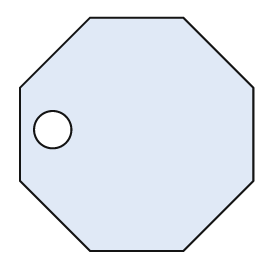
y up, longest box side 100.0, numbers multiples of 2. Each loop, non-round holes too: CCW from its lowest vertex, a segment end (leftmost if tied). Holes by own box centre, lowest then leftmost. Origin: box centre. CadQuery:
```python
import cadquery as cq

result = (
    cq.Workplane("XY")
    .moveTo(-20.0, -50.0)
    .lineTo(20.0, -50.0)
    .lineTo(50.0, -20.0)
    .lineTo(50.0, 20.0)
    .lineTo(20.0, 50.0)
    .lineTo(-20.0, 50.0)
    .lineTo(-50.0, 20.0)
    .lineTo(-50.0, -20.0)
    .close()
    .moveTo(-36.0, 2.0)
    .circle(8.0)
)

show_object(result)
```